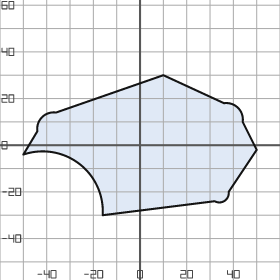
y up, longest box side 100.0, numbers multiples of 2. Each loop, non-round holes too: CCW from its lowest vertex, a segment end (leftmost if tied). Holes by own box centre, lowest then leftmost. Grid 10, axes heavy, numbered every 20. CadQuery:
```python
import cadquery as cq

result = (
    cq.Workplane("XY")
    .moveTo(-16.0, -30.0)
    .lineTo(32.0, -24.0)
    .threePointArc((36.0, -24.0), (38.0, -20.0))
    .lineTo(50.0, -2.0)
    .lineTo(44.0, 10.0)
    .threePointArc((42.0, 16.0), (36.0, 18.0))
    .lineTo(10.0, 30.0)
    .lineTo(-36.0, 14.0)
    .threePointArc((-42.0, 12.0), (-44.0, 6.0))
    .lineTo(-50.0, -4.0)
    .threePointArc((-26.0, -8.0), (-16.0, -30.0))
    .close()
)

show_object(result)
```